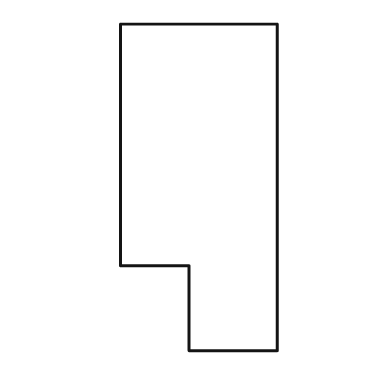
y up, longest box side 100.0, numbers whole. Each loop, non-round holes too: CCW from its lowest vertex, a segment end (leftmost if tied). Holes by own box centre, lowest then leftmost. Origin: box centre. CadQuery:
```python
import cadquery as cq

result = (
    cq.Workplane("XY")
    .moveTo(-3.0, -50.0)
    .lineTo(24.0, -50.0)
    .lineTo(24.0, 50.0)
    .lineTo(-24.0, 50.0)
    .lineTo(-24.0, -24.0)
    .lineTo(-3.0, -24.0)
    .close()
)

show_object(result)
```